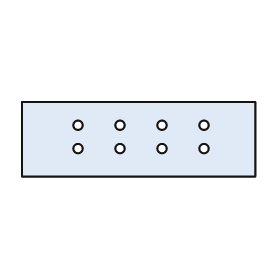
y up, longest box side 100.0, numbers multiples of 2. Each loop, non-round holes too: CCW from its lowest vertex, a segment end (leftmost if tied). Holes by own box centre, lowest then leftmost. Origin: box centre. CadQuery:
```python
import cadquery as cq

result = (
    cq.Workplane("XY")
    .moveTo(-50.0, -16.0)
    .lineTo(50.0, -16.0)
    .lineTo(50.0, 16.0)
    .lineTo(-50.0, 16.0)
    .close()
    .moveTo(-26.0, -4.0)
    .circle(2.0)
    .moveTo(-8.0, -4.0)
    .circle(2.0)
    .moveTo(10.0, -4.0)
    .circle(2.0)
    .moveTo(28.0, -4.0)
    .circle(2.0)
    .moveTo(-26.0, 6.0)
    .circle(2.0)
    .moveTo(-8.0, 6.0)
    .circle(2.0)
    .moveTo(10.0, 6.0)
    .circle(2.0)
    .moveTo(28.0, 6.0)
    .circle(2.0)
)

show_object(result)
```